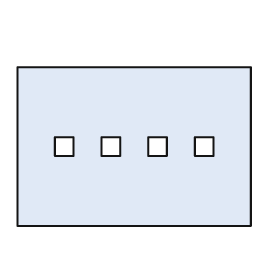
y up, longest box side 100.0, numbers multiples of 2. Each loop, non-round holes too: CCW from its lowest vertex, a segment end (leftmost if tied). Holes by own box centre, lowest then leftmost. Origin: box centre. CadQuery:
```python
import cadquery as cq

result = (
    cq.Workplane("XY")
    .moveTo(-50.0, -34.0)
    .lineTo(50.0, -34.0)
    .lineTo(50.0, 34.0)
    .lineTo(-50.0, 34.0)
    .close()
    .moveTo(-34.0, -4.0)
    .lineTo(-26.0, -4.0)
    .lineTo(-26.0, 4.0)
    .lineTo(-34.0, 4.0)
    .close()
    .moveTo(-14.0, -4.0)
    .lineTo(-6.0, -4.0)
    .lineTo(-6.0, 4.0)
    .lineTo(-14.0, 4.0)
    .close()
    .moveTo(6.0, -4.0)
    .lineTo(14.0, -4.0)
    .lineTo(14.0, 4.0)
    .lineTo(6.0, 4.0)
    .close()
    .moveTo(26.0, -4.0)
    .lineTo(34.0, -4.0)
    .lineTo(34.0, 4.0)
    .lineTo(26.0, 4.0)
    .close()
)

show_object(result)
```